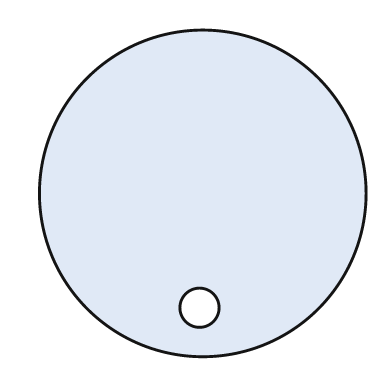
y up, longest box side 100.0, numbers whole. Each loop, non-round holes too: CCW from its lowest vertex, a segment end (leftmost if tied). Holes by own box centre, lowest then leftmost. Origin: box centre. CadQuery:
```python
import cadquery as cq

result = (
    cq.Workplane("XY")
    .moveTo(0.0, 0.0)
    .circle(50.0)
    .moveTo(-1.0, -35.0)
    .circle(6.0)
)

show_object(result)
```